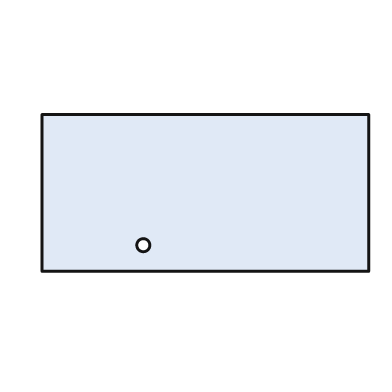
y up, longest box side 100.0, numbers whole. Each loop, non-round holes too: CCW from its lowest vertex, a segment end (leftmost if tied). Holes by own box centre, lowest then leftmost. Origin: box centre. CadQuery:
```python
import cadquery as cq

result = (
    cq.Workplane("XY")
    .moveTo(-50.0, -24.0)
    .lineTo(50.0, -24.0)
    .lineTo(50.0, 24.0)
    .lineTo(-50.0, 24.0)
    .close()
    .moveTo(-19.0, -16.0)
    .circle(2.0)
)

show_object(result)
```